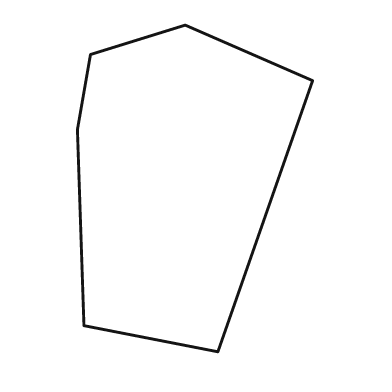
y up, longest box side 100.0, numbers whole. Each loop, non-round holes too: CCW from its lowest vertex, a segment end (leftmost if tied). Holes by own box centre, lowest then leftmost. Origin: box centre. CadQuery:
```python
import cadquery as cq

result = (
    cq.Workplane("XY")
    .moveTo(7.0, -50.0)
    .lineTo(36.0, 33.0)
    .lineTo(-3.0, 50.0)
    .lineTo(-32.0, 41.0)
    .lineTo(-36.0, 18.0)
    .lineTo(-34.0, -42.0)
    .close()
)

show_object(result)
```